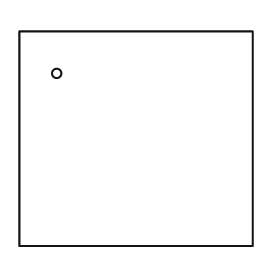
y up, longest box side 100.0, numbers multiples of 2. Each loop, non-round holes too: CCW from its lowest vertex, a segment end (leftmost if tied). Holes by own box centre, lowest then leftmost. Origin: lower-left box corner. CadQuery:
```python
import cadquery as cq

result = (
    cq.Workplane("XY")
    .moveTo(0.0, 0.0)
    .lineTo(100.0, 0.0)
    .lineTo(100.0, 92.0)
    .lineTo(0.0, 92.0)
    .close()
    .moveTo(16.0, 74.0)
    .circle(2.0)
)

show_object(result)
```